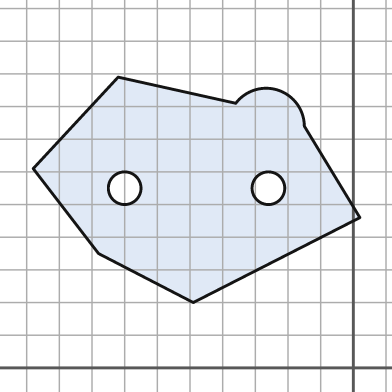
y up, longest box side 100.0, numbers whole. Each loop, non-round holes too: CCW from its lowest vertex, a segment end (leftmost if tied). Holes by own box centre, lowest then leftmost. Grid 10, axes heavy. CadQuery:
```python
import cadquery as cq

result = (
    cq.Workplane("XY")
    .moveTo(-49.0, 20.0)
    .lineTo(2.0, 46.0)
    .lineTo(-15.0, 74.0)
    .threePointArc((-23.0, 85.0), (-36.0, 81.0))
    .lineTo(-72.0, 89.0)
    .lineTo(-98.0, 61.0)
    .lineTo(-78.0, 35.0)
    .close()
    .moveTo(-70.0, 55.0)
    .circle(5.0)
    .moveTo(-26.0, 55.0)
    .circle(5.0)
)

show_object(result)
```